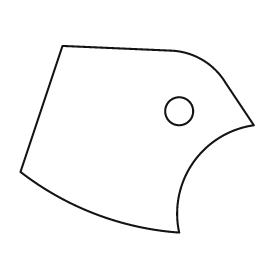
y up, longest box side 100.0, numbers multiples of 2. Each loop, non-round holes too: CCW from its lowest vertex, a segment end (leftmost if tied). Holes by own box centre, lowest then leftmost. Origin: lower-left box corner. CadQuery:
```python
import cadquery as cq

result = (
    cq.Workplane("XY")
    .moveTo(68.0, 0.0)
    .threePointArc((74.0, 30.0), (100.0, 46.0))
    .lineTo(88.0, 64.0)
    .threePointArc((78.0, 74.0), (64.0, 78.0))
    .lineTo(18.0, 80.0)
    .lineTo(0.0, 26.0)
    .threePointArc((32.0, 8.0), (68.0, 0.0))
    .close()
    .moveTo(68.0, 52.0)
    .circle(6.0)
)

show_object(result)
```